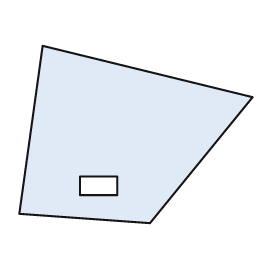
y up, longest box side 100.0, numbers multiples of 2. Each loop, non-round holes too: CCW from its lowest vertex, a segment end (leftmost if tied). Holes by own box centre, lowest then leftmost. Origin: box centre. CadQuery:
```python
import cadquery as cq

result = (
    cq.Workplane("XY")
    .moveTo(6.0, -38.0)
    .lineTo(50.0, 16.0)
    .lineTo(-40.0, 38.0)
    .lineTo(-50.0, -34.0)
    .close()
    .moveTo(-24.0, -26.0)
    .lineTo(-8.0, -26.0)
    .lineTo(-8.0, -18.0)
    .lineTo(-24.0, -18.0)
    .close()
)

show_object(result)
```